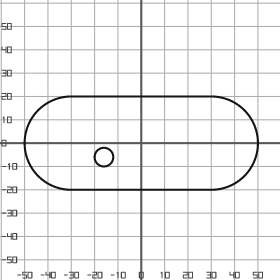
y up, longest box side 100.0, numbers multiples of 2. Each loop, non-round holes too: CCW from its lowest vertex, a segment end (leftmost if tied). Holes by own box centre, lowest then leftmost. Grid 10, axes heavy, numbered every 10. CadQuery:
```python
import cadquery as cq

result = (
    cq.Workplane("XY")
    .moveTo(-30.0, -20.0)
    .lineTo(30.0, -20.0)
    .threePointArc((50.0, 0.0), (30.0, 20.0))
    .lineTo(-30.0, 20.0)
    .threePointArc((-50.0, 0.0), (-30.0, -20.0))
    .close()
    .moveTo(-16.0, -6.0)
    .circle(4.0)
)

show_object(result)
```